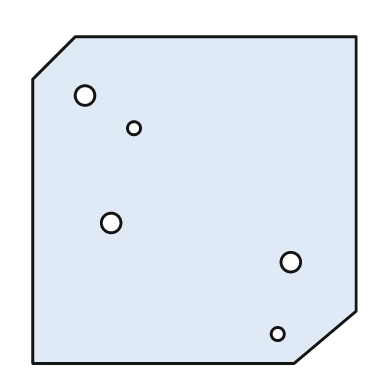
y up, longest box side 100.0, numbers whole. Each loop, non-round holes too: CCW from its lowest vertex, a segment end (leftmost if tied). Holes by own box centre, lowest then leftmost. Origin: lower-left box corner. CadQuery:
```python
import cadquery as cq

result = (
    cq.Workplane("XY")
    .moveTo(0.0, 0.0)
    .lineTo(80.0, 0.0)
    .lineTo(99.0, 16.0)
    .lineTo(99.0, 100.0)
    .lineTo(13.0, 100.0)
    .lineTo(0.0, 87.0)
    .close()
    .moveTo(75.0, 9.0)
    .circle(2.0)
    .moveTo(79.0, 31.0)
    .circle(3.0)
    .moveTo(24.0, 43.0)
    .circle(3.0)
    .moveTo(31.0, 72.0)
    .circle(2.0)
    .moveTo(16.0, 82.0)
    .circle(3.0)
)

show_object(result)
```